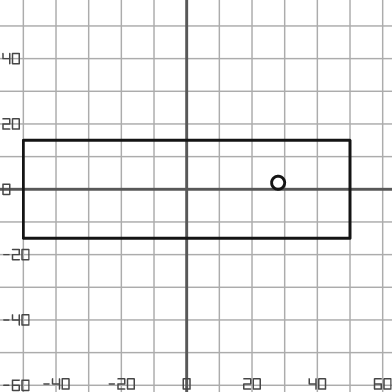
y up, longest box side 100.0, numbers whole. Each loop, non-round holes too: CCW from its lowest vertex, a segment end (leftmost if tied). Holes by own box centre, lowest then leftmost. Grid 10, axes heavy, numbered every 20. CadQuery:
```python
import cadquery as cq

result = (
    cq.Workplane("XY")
    .moveTo(-50.0, -15.0)
    .lineTo(50.0, -15.0)
    .lineTo(50.0, 15.0)
    .lineTo(-50.0, 15.0)
    .close()
    .moveTo(28.0, 2.0)
    .circle(2.0)
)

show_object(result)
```